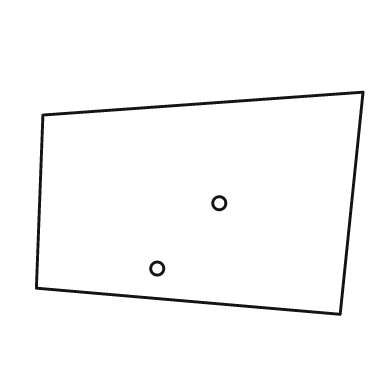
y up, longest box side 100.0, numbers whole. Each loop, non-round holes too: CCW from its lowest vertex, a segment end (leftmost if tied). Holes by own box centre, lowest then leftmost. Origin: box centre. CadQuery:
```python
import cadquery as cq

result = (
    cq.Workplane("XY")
    .moveTo(43.0, -34.0)
    .lineTo(50.0, 34.0)
    .lineTo(-48.0, 27.0)
    .lineTo(-50.0, -26.0)
    .close()
    .moveTo(-13.0, -20.0)
    .circle(2.0)
    .moveTo(6.0, 0.0)
    .circle(2.0)
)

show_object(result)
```